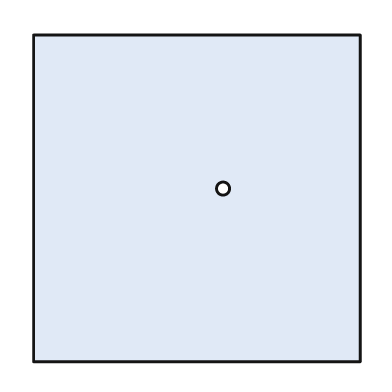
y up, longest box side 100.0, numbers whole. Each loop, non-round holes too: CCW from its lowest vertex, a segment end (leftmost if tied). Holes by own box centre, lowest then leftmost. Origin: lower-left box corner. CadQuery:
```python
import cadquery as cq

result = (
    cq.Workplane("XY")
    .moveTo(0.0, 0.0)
    .lineTo(100.0, 0.0)
    .lineTo(100.0, 100.0)
    .lineTo(0.0, 100.0)
    .close()
    .moveTo(58.0, 53.0)
    .circle(2.0)
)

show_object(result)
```